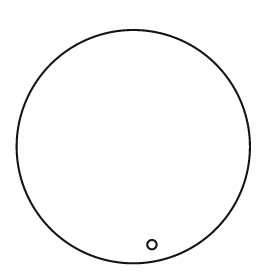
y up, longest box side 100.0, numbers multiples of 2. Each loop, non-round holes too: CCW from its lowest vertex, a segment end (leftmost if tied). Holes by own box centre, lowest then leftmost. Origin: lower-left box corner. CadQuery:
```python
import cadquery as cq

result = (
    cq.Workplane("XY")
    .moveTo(50.0, 50.0)
    .circle(50.0)
    .moveTo(58.0, 8.0)
    .circle(2.0)
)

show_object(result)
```